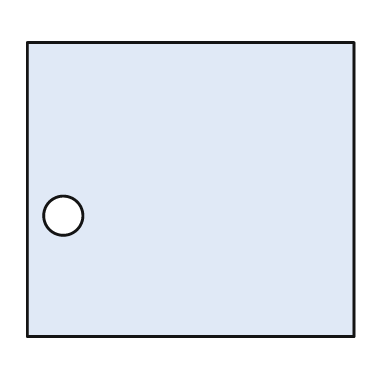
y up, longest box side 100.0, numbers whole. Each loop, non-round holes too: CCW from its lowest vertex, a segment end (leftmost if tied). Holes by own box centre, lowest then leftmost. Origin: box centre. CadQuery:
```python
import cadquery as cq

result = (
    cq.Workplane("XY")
    .moveTo(-50.0, -45.0)
    .lineTo(50.0, -45.0)
    .lineTo(50.0, 45.0)
    .lineTo(-50.0, 45.0)
    .close()
    .moveTo(-39.0, -8.0)
    .circle(6.0)
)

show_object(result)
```